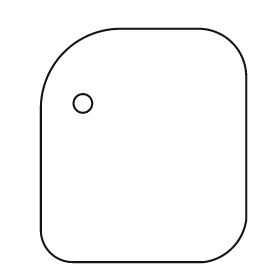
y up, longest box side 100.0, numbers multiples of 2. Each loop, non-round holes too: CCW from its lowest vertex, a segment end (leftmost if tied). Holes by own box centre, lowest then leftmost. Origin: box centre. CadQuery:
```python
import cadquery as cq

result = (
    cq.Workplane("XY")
    .moveTo(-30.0, -50.0)
    .lineTo(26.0, -50.0)
    .threePointArc((38.0, -44.0), (44.0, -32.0))
    .lineTo(44.0, 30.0)
    .threePointArc((38.0, 44.0), (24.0, 50.0))
    .lineTo(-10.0, 50.0)
    .threePointArc((-34.0, 40.0), (-44.0, 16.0))
    .lineTo(-44.0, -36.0)
    .threePointArc((-40.0, -46.0), (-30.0, -50.0))
    .close()
    .moveTo(-26.0, 18.0)
    .circle(4.0)
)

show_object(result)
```